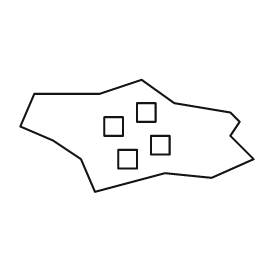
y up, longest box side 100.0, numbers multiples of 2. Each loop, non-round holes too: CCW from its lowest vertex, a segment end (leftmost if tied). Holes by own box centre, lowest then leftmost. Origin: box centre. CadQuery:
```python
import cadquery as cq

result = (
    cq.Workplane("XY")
    .moveTo(-18.0, -24.0)
    .lineTo(12.0, -16.0)
    .lineTo(32.0, -18.0)
    .lineTo(50.0, -10.0)
    .lineTo(40.0, 0.0)
    .lineTo(44.0, 6.0)
    .lineTo(40.0, 10.0)
    .lineTo(16.0, 14.0)
    .lineTo(2.0, 24.0)
    .lineTo(-16.0, 18.0)
    .lineTo(-44.0, 18.0)
    .lineTo(-50.0, 4.0)
    .lineTo(-36.0, -2.0)
    .lineTo(-24.0, -10.0)
    .close()
    .moveTo(-8.0, -14.0)
    .lineTo(0.0, -14.0)
    .lineTo(0.0, -6.0)
    .lineTo(-8.0, -6.0)
    .close()
    .moveTo(6.0, -8.0)
    .lineTo(14.0, -8.0)
    .lineTo(14.0, 0.0)
    .lineTo(6.0, 0.0)
    .close()
    .moveTo(-14.0, 0.0)
    .lineTo(-6.0, 0.0)
    .lineTo(-6.0, 8.0)
    .lineTo(-14.0, 8.0)
    .close()
    .moveTo(0.0, 6.0)
    .lineTo(8.0, 6.0)
    .lineTo(8.0, 14.0)
    .lineTo(0.0, 14.0)
    .close()
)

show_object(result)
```